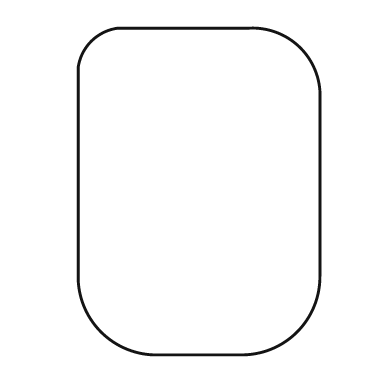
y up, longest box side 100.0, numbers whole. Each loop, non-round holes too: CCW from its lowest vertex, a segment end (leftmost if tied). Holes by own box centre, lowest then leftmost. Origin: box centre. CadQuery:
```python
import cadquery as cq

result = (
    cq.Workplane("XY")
    .moveTo(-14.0, -50.0)
    .lineTo(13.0, -50.0)
    .threePointArc((30.0, -43.0), (37.0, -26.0))
    .lineTo(37.0, 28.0)
    .threePointArc((31.0, 44.0), (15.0, 50.0))
    .lineTo(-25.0, 50.0)
    .threePointArc((-33.0, 46.0), (-37.0, 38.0))
    .lineTo(-37.0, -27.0)
    .threePointArc((-30.0, -43.0), (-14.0, -50.0))
    .close()
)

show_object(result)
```